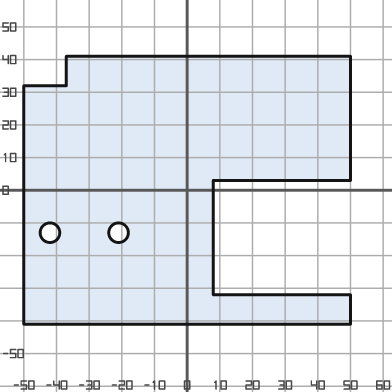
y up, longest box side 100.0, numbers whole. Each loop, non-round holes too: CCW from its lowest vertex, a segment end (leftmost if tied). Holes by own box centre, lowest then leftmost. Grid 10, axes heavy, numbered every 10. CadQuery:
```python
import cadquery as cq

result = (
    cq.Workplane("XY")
    .moveTo(-50.0, -41.0)
    .lineTo(50.0, -41.0)
    .lineTo(50.0, -32.0)
    .lineTo(8.0, -32.0)
    .lineTo(8.0, 3.0)
    .lineTo(50.0, 3.0)
    .lineTo(50.0, 41.0)
    .lineTo(-37.0, 41.0)
    .lineTo(-37.0, 32.0)
    .lineTo(-50.0, 32.0)
    .close()
    .moveTo(-42.0, -13.0)
    .circle(3.0)
    .moveTo(-21.0, -13.0)
    .circle(3.0)
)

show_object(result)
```